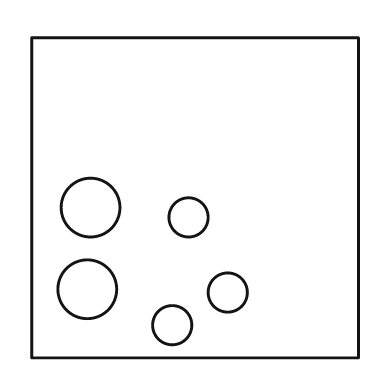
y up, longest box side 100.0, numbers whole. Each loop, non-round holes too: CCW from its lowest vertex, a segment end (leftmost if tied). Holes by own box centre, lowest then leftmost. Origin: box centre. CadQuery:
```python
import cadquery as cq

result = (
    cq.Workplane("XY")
    .moveTo(-50.0, -49.0)
    .lineTo(50.0, -49.0)
    .lineTo(50.0, 49.0)
    .lineTo(-50.0, 49.0)
    .close()
    .moveTo(-7.0, -39.0)
    .circle(6.0)
    .moveTo(10.0, -29.0)
    .circle(6.0)
    .moveTo(-33.0, -28.0)
    .circle(9.0)
    .moveTo(-2.0, -6.0)
    .circle(6.0)
    .moveTo(-32.0, -3.0)
    .circle(9.0)
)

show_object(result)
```